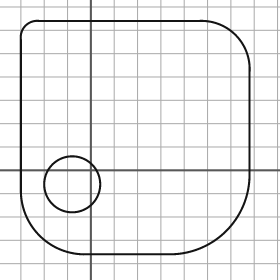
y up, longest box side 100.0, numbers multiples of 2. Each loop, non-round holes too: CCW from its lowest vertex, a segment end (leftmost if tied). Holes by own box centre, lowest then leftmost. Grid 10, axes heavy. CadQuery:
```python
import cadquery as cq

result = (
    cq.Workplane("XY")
    .moveTo(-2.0, -36.0)
    .lineTo(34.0, -36.0)
    .threePointArc((58.0, -26.0), (68.0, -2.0))
    .lineTo(68.0, 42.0)
    .threePointArc((62.0, 58.0), (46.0, 64.0))
    .lineTo(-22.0, 64.0)
    .threePointArc((-28.0, 62.0), (-30.0, 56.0))
    .lineTo(-30.0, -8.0)
    .threePointArc((-22.0, -28.0), (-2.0, -36.0))
    .close()
    .moveTo(-8.0, -6.0)
    .circle(12.0)
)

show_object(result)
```